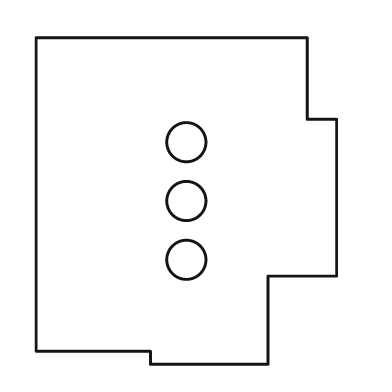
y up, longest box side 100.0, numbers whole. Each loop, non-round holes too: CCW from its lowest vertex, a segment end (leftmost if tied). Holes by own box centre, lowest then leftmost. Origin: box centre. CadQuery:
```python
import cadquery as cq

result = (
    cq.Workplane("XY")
    .moveTo(-11.0, -50.0)
    .lineTo(25.0, -50.0)
    .lineTo(25.0, -23.0)
    .lineTo(46.0, -23.0)
    .lineTo(46.0, 25.0)
    .lineTo(37.0, 25.0)
    .lineTo(37.0, 50.0)
    .lineTo(-46.0, 50.0)
    .lineTo(-46.0, -46.0)
    .lineTo(-11.0, -46.0)
    .close()
    .moveTo(0.0, -18.0)
    .circle(6.0)
    .moveTo(0.0, 0.0)
    .circle(6.0)
    .moveTo(0.0, 18.0)
    .circle(6.0)
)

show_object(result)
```